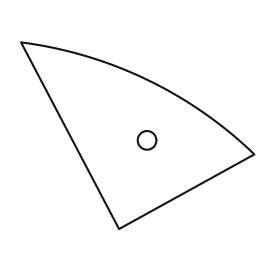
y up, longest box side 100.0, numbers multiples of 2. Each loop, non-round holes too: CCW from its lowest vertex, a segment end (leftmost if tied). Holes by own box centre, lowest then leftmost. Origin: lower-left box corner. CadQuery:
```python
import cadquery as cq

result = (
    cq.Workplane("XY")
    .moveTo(42.0, 0.0)
    .lineTo(100.0, 32.0)
    .threePointArc((54.0, 64.0), (0.0, 80.0))
    .close()
    .moveTo(54.0, 38.0)
    .circle(4.0)
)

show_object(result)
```